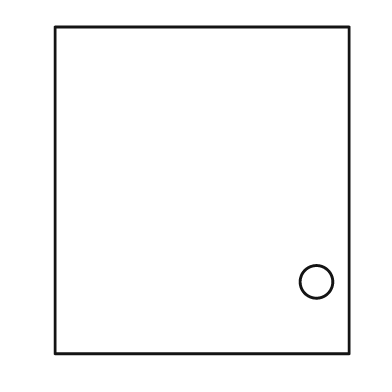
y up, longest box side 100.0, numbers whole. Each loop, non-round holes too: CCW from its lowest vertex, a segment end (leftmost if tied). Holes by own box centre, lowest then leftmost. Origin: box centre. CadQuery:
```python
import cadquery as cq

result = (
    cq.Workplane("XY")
    .moveTo(-45.0, -50.0)
    .lineTo(45.0, -50.0)
    .lineTo(45.0, 50.0)
    .lineTo(-45.0, 50.0)
    .close()
    .moveTo(35.0, -28.0)
    .circle(5.0)
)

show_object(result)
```